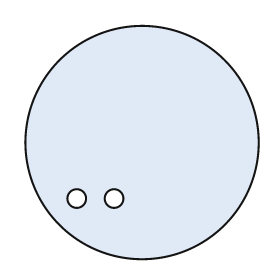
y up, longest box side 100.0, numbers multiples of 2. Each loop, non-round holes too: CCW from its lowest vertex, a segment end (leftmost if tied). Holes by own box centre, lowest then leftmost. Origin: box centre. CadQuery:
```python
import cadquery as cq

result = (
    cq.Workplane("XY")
    .moveTo(0.0, 0.0)
    .circle(50.0)
    .moveTo(-28.0, -24.0)
    .circle(4.0)
    .moveTo(-12.0, -24.0)
    .circle(4.0)
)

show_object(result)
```